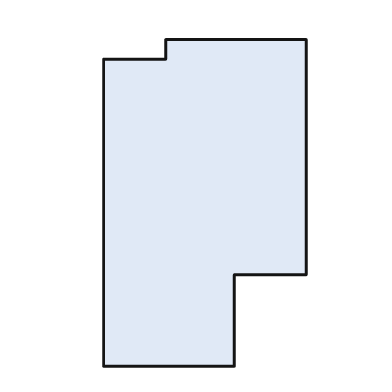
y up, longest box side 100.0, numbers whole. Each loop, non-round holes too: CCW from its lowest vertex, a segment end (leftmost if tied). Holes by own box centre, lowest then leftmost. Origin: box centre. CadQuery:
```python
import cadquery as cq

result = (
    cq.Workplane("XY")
    .moveTo(-31.0, -50.0)
    .lineTo(9.0, -50.0)
    .lineTo(9.0, -22.0)
    .lineTo(31.0, -22.0)
    .lineTo(31.0, 50.0)
    .lineTo(-12.0, 50.0)
    .lineTo(-12.0, 44.0)
    .lineTo(-31.0, 44.0)
    .close()
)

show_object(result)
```